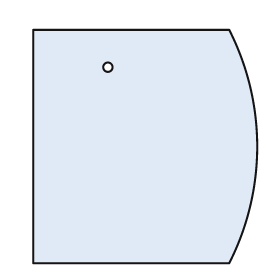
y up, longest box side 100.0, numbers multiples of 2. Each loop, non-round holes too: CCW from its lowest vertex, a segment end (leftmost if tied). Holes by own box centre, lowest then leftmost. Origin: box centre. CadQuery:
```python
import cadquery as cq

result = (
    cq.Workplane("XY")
    .moveTo(-48.0, -50.0)
    .lineTo(36.0, -50.0)
    .threePointArc((48.0, 0.0), (36.0, 50.0))
    .lineTo(-48.0, 50.0)
    .close()
    .moveTo(-16.0, 34.0)
    .circle(2.0)
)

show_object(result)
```